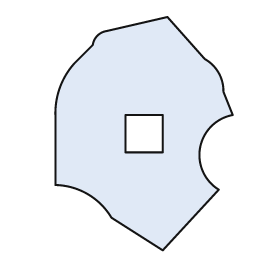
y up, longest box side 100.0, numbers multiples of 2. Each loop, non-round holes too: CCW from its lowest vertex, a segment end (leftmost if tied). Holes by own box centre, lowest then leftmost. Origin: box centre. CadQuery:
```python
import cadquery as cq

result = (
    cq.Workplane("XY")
    .moveTo(8.0, -50.0)
    .lineTo(32.0, -24.0)
    .threePointArc((24.0, -6.0), (38.0, 8.0))
    .lineTo(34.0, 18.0)
    .threePointArc((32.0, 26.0), (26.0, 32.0))
    .lineTo(10.0, 50.0)
    .lineTo(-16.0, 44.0)
    .threePointArc((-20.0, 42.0), (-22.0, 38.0))
    .lineTo(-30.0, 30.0)
    .threePointArc((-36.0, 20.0), (-38.0, 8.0))
    .lineTo(-38.0, -22.0)
    .threePointArc((-24.0, -26.0), (-14.0, -36.0))
    .close()
    .moveTo(-8.0, -8.0)
    .lineTo(8.0, -8.0)
    .lineTo(8.0, 8.0)
    .lineTo(-8.0, 8.0)
    .close()
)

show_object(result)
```